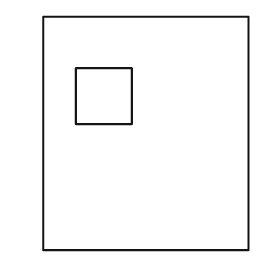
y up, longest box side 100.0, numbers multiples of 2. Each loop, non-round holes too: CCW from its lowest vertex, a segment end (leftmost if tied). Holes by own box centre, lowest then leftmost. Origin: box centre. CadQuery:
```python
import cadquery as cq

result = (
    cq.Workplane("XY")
    .moveTo(-44.0, -50.0)
    .lineTo(44.0, -50.0)
    .lineTo(44.0, 50.0)
    .lineTo(-44.0, 50.0)
    .close()
    .moveTo(-30.0, 4.0)
    .lineTo(-6.0, 4.0)
    .lineTo(-6.0, 28.0)
    .lineTo(-30.0, 28.0)
    .close()
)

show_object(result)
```